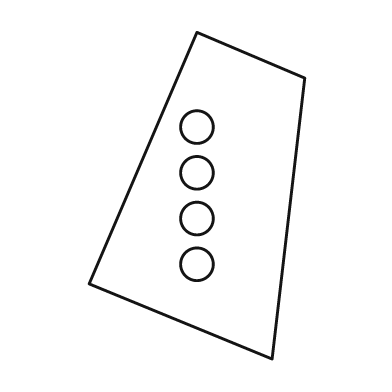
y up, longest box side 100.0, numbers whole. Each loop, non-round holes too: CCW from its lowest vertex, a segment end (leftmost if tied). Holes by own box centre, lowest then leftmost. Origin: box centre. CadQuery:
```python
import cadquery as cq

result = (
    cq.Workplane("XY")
    .moveTo(23.0, -50.0)
    .lineTo(33.0, 36.0)
    .lineTo(0.0, 50.0)
    .lineTo(-33.0, -27.0)
    .close()
    .moveTo(0.0, -21.0)
    .circle(5.0)
    .moveTo(0.0, -7.0)
    .circle(5.0)
    .moveTo(0.0, 7.0)
    .circle(5.0)
    .moveTo(0.0, 21.0)
    .circle(5.0)
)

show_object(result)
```